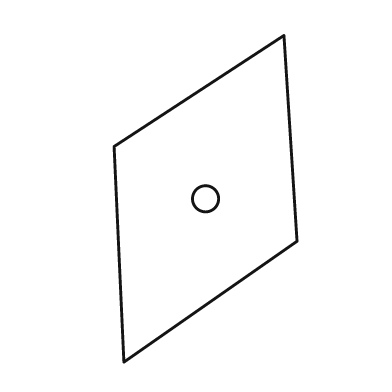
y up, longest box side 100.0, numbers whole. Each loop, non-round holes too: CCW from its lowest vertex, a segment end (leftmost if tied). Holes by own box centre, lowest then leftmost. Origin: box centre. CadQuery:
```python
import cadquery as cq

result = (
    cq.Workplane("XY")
    .moveTo(-25.0, -50.0)
    .lineTo(28.0, -13.0)
    .lineTo(24.0, 50.0)
    .lineTo(-28.0, 16.0)
    .close()
    .moveTo(0.0, 0.0)
    .circle(4.0)
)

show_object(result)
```